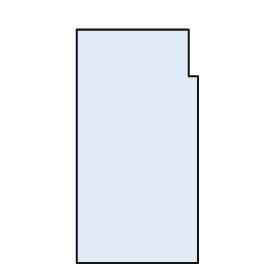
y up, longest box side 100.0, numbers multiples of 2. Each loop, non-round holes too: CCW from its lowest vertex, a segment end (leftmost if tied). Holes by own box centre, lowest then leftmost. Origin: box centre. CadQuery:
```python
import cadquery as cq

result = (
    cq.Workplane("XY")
    .moveTo(-26.0, -50.0)
    .lineTo(26.0, -50.0)
    .lineTo(26.0, 30.0)
    .lineTo(22.0, 30.0)
    .lineTo(22.0, 50.0)
    .lineTo(-26.0, 50.0)
    .close()
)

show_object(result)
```